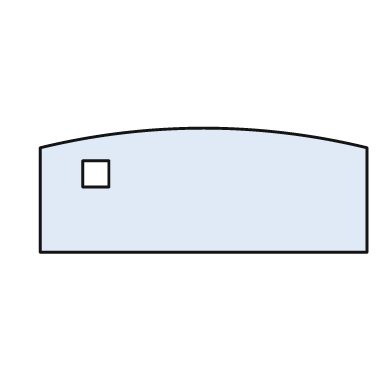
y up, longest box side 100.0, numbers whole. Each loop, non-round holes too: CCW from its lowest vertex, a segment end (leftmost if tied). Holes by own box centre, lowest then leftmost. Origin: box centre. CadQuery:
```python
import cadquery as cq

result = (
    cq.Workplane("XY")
    .moveTo(-50.0, -19.0)
    .lineTo(50.0, -19.0)
    .lineTo(50.0, 13.0)
    .threePointArc((0.0, 19.0), (-50.0, 13.0))
    .close()
    .moveTo(-37.0, 1.0)
    .lineTo(-29.0, 1.0)
    .lineTo(-29.0, 9.0)
    .lineTo(-37.0, 9.0)
    .close()
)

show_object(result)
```